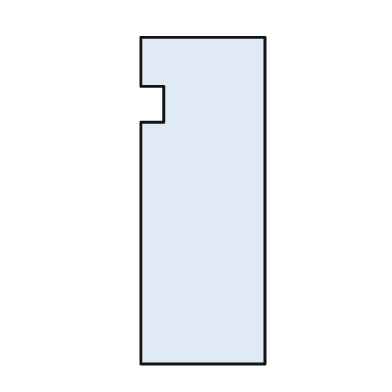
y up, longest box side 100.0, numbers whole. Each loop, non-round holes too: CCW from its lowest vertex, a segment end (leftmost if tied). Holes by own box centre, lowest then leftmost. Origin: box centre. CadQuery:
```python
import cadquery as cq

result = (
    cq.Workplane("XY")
    .moveTo(-19.0, -50.0)
    .lineTo(19.0, -50.0)
    .lineTo(19.0, 50.0)
    .lineTo(-19.0, 50.0)
    .lineTo(-19.0, 35.0)
    .lineTo(-12.0, 35.0)
    .lineTo(-12.0, 24.0)
    .lineTo(-19.0, 24.0)
    .close()
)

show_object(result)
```